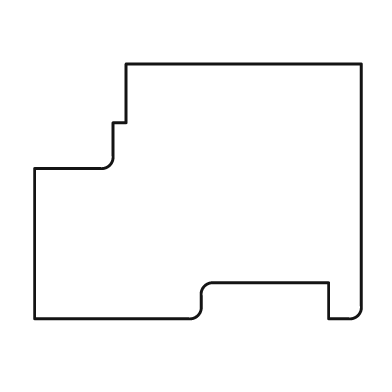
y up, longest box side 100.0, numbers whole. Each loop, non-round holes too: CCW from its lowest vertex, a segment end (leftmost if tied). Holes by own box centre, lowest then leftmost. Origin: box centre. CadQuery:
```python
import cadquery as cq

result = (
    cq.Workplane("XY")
    .moveTo(-50.0, -39.0)
    .lineTo(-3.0, -39.0)
    .threePointArc((0.0, -38.0), (1.0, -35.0))
    .lineTo(1.0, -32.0)
    .threePointArc((2.0, -29.0), (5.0, -28.0))
    .lineTo(40.0, -28.0)
    .lineTo(40.0, -39.0)
    .lineTo(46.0, -39.0)
    .threePointArc((49.0, -38.0), (50.0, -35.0))
    .lineTo(50.0, 39.0)
    .lineTo(-22.0, 39.0)
    .lineTo(-22.0, 21.0)
    .lineTo(-26.0, 21.0)
    .lineTo(-26.0, 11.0)
    .threePointArc((-27.0, 8.0), (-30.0, 7.0))
    .lineTo(-50.0, 7.0)
    .close()
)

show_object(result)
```